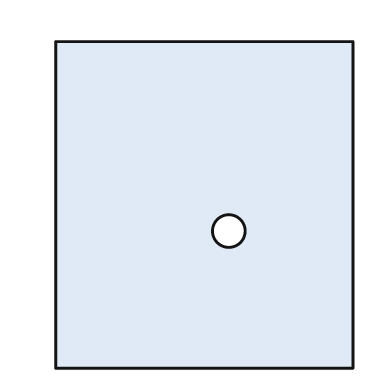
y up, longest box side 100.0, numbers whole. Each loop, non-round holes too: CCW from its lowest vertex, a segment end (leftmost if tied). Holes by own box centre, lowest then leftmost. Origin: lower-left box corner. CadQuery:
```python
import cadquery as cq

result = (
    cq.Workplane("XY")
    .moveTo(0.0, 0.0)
    .lineTo(91.0, 0.0)
    .lineTo(91.0, 100.0)
    .lineTo(0.0, 100.0)
    .close()
    .moveTo(53.0, 42.0)
    .circle(5.0)
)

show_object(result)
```